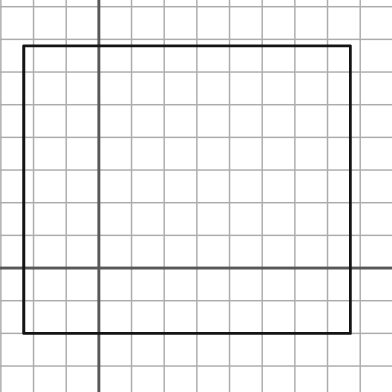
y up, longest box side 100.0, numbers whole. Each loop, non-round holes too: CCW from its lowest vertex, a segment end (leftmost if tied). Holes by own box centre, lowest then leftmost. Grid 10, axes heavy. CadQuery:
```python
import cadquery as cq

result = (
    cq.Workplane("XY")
    .moveTo(-23.0, -20.0)
    .lineTo(77.0, -20.0)
    .lineTo(77.0, 68.0)
    .lineTo(-23.0, 68.0)
    .close()
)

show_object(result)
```